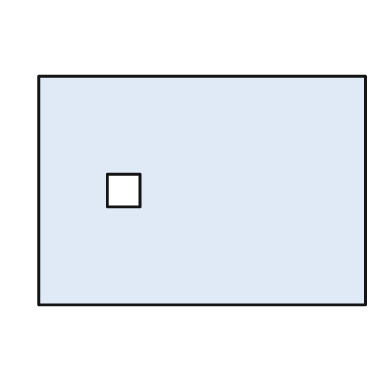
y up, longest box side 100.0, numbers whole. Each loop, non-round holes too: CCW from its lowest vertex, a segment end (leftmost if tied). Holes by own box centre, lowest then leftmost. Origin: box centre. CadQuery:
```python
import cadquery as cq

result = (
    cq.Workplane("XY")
    .moveTo(-50.0, -35.0)
    .lineTo(50.0, -35.0)
    .lineTo(50.0, 35.0)
    .lineTo(-50.0, 35.0)
    .close()
    .moveTo(-29.0, -5.0)
    .lineTo(-19.0, -5.0)
    .lineTo(-19.0, 5.0)
    .lineTo(-29.0, 5.0)
    .close()
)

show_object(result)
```